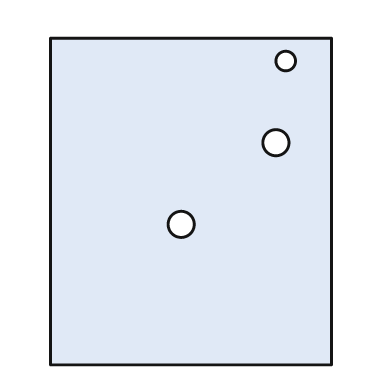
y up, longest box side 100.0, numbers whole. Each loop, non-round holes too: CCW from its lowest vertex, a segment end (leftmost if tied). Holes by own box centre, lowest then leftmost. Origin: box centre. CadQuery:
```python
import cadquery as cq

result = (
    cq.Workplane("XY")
    .moveTo(-43.0, -50.0)
    .lineTo(43.0, -50.0)
    .lineTo(43.0, 50.0)
    .lineTo(-43.0, 50.0)
    .close()
    .moveTo(-3.0, -7.0)
    .circle(4.0)
    .moveTo(26.0, 18.0)
    .circle(4.0)
    .moveTo(29.0, 43.0)
    .circle(3.0)
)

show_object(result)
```